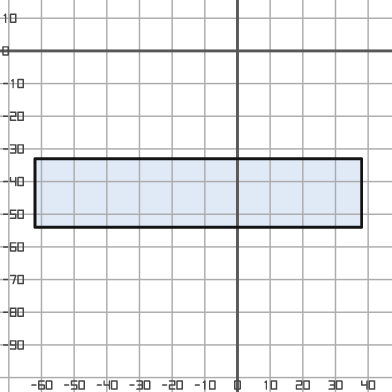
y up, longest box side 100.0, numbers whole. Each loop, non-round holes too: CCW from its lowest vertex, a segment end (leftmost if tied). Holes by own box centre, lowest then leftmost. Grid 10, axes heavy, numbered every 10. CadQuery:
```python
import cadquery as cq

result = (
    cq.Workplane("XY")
    .moveTo(-62.0, -54.0)
    .lineTo(38.0, -54.0)
    .lineTo(38.0, -33.0)
    .lineTo(-62.0, -33.0)
    .close()
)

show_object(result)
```